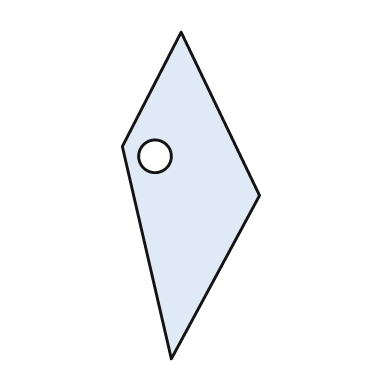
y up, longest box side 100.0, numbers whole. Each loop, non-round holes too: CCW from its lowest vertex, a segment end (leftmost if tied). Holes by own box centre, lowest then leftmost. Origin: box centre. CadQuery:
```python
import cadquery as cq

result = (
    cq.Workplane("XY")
    .moveTo(-6.0, -50.0)
    .lineTo(21.0, 0.0)
    .lineTo(-3.0, 50.0)
    .lineTo(-21.0, 15.0)
    .close()
    .moveTo(-11.0, 12.0)
    .circle(5.0)
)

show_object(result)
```